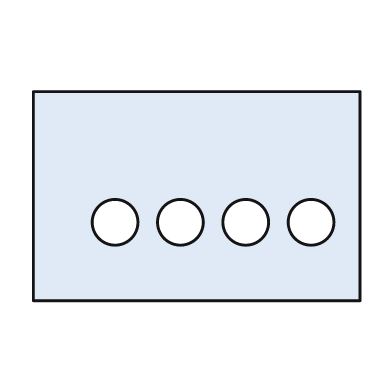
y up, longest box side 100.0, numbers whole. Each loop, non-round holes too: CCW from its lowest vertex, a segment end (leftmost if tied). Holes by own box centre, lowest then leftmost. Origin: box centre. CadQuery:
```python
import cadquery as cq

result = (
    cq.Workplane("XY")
    .moveTo(-50.0, -32.0)
    .lineTo(50.0, -32.0)
    .lineTo(50.0, 32.0)
    .lineTo(-50.0, 32.0)
    .close()
    .moveTo(-25.0, -8.0)
    .circle(7.0)
    .moveTo(-5.0, -8.0)
    .circle(7.0)
    .moveTo(15.0, -8.0)
    .circle(7.0)
    .moveTo(35.0, -8.0)
    .circle(7.0)
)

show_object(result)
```